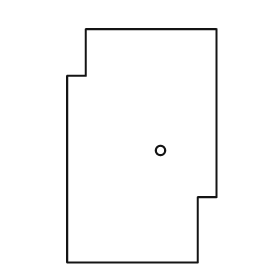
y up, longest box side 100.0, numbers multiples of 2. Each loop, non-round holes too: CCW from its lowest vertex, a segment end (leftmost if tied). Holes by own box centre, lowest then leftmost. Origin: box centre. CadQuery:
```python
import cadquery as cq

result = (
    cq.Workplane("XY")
    .moveTo(-32.0, -50.0)
    .lineTo(24.0, -50.0)
    .lineTo(24.0, -22.0)
    .lineTo(32.0, -22.0)
    .lineTo(32.0, 50.0)
    .lineTo(-24.0, 50.0)
    .lineTo(-24.0, 30.0)
    .lineTo(-32.0, 30.0)
    .close()
    .moveTo(8.0, -2.0)
    .circle(2.0)
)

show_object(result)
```